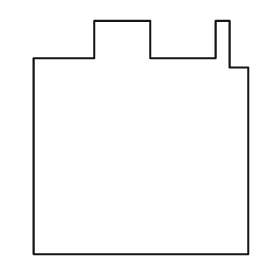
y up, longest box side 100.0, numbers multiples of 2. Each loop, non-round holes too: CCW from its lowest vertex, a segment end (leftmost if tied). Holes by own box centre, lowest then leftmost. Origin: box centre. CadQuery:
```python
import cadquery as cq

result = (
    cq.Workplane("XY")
    .moveTo(-46.0, -50.0)
    .lineTo(46.0, -50.0)
    .lineTo(46.0, 30.0)
    .lineTo(38.0, 30.0)
    .lineTo(38.0, 50.0)
    .lineTo(32.0, 50.0)
    .lineTo(32.0, 34.0)
    .lineTo(4.0, 34.0)
    .lineTo(4.0, 50.0)
    .lineTo(-20.0, 50.0)
    .lineTo(-20.0, 34.0)
    .lineTo(-46.0, 34.0)
    .close()
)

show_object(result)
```